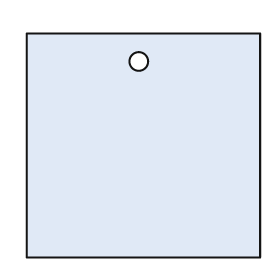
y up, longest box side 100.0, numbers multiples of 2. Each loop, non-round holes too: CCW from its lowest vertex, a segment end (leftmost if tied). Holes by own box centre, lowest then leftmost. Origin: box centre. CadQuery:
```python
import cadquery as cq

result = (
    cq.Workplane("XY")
    .moveTo(-50.0, -48.0)
    .lineTo(50.0, -48.0)
    .lineTo(50.0, 48.0)
    .lineTo(-50.0, 48.0)
    .close()
    .moveTo(-2.0, 36.0)
    .circle(4.0)
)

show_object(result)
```